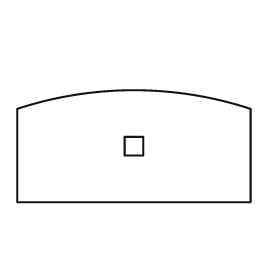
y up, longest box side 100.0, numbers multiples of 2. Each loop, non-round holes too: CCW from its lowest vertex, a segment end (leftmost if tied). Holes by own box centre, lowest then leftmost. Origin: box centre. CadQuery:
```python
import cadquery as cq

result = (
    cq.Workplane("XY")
    .moveTo(-50.0, -24.0)
    .lineTo(50.0, -24.0)
    .lineTo(50.0, 16.0)
    .threePointArc((0.0, 24.0), (-50.0, 16.0))
    .close()
    .moveTo(-4.0, -4.0)
    .lineTo(4.0, -4.0)
    .lineTo(4.0, 4.0)
    .lineTo(-4.0, 4.0)
    .close()
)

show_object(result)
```